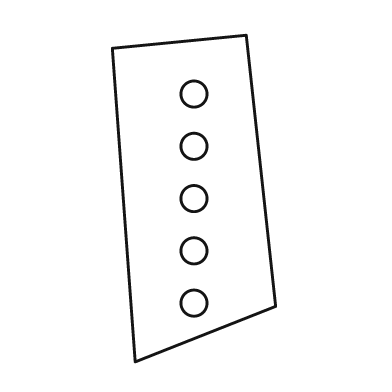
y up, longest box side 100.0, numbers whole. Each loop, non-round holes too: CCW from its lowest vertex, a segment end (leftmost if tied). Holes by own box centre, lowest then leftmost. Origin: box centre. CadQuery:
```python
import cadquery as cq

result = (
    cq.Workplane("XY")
    .moveTo(-18.0, -50.0)
    .lineTo(25.0, -33.0)
    .lineTo(16.0, 50.0)
    .lineTo(-25.0, 46.0)
    .close()
    .moveTo(0.0, -32.0)
    .circle(4.0)
    .moveTo(0.0, -16.0)
    .circle(4.0)
    .moveTo(0.0, 0.0)
    .circle(4.0)
    .moveTo(0.0, 16.0)
    .circle(4.0)
    .moveTo(0.0, 32.0)
    .circle(4.0)
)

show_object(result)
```